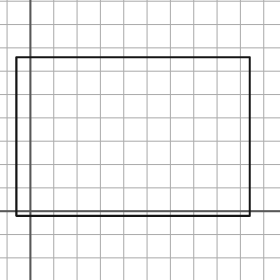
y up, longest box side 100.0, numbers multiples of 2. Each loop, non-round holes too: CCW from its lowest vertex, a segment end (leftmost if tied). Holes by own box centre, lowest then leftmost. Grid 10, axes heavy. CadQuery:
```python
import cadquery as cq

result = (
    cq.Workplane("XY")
    .moveTo(-6.0, -2.0)
    .lineTo(94.0, -2.0)
    .lineTo(94.0, 66.0)
    .lineTo(-6.0, 66.0)
    .close()
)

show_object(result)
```